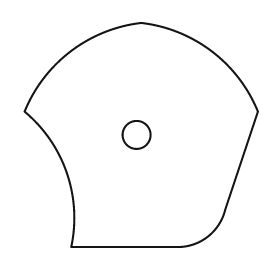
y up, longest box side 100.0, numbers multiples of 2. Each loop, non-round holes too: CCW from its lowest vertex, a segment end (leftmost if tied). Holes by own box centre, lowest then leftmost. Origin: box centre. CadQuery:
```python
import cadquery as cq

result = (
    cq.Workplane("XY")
    .moveTo(-30.0, -48.0)
    .lineTo(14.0, -48.0)
    .threePointArc((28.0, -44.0), (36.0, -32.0))
    .lineTo(50.0, 10.0)
    .threePointArc((30.0, 36.0), (0.0, 48.0))
    .threePointArc((-30.0, 36.0), (-50.0, 10.0))
    .threePointArc((-32.0, -16.0), (-30.0, -48.0))
    .close()
    .moveTo(-2.0, 0.0)
    .circle(6.0)
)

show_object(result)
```